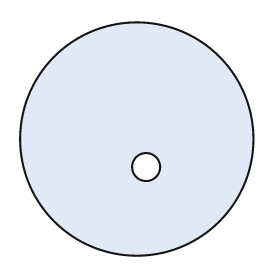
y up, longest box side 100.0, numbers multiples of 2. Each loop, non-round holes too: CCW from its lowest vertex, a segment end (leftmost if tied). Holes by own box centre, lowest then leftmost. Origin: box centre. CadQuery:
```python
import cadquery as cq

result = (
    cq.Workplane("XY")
    .moveTo(0.0, 0.0)
    .circle(50.0)
    .moveTo(4.0, -12.0)
    .circle(6.0)
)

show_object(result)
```